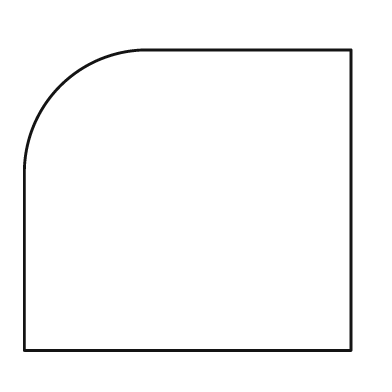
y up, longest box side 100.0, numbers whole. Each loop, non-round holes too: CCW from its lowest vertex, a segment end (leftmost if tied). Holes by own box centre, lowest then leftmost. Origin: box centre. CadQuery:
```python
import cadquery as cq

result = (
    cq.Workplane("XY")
    .moveTo(-50.0, -46.0)
    .lineTo(50.0, -46.0)
    .lineTo(50.0, 46.0)
    .lineTo(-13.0, 46.0)
    .threePointArc((-39.0, 35.0), (-50.0, 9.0))
    .close()
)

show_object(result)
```